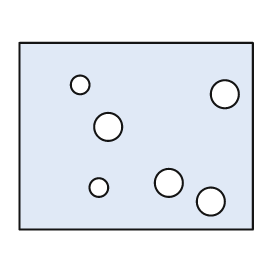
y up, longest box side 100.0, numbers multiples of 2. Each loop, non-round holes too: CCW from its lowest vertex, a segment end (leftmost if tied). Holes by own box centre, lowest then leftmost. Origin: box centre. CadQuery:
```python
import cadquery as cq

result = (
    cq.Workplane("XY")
    .moveTo(-50.0, -40.0)
    .lineTo(50.0, -40.0)
    .lineTo(50.0, 40.0)
    .lineTo(-50.0, 40.0)
    .close()
    .moveTo(32.0, -28.0)
    .circle(6.0)
    .moveTo(-16.0, -22.0)
    .circle(4.0)
    .moveTo(14.0, -20.0)
    .circle(6.0)
    .moveTo(-12.0, 4.0)
    .circle(6.0)
    .moveTo(38.0, 18.0)
    .circle(6.0)
    .moveTo(-24.0, 22.0)
    .circle(4.0)
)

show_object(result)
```